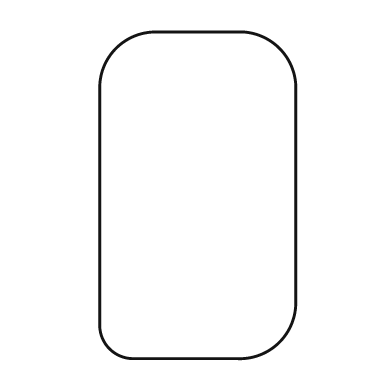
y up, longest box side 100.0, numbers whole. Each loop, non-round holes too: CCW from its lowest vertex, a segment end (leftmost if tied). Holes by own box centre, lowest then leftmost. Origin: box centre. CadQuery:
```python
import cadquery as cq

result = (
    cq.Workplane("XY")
    .moveTo(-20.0, -50.0)
    .lineTo(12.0, -50.0)
    .threePointArc((25.0, -45.0), (30.0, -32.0))
    .lineTo(30.0, 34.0)
    .threePointArc((25.0, 45.0), (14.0, 50.0))
    .lineTo(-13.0, 50.0)
    .threePointArc((-25.0, 45.0), (-30.0, 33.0))
    .lineTo(-30.0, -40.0)
    .threePointArc((-27.0, -47.0), (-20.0, -50.0))
    .close()
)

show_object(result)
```